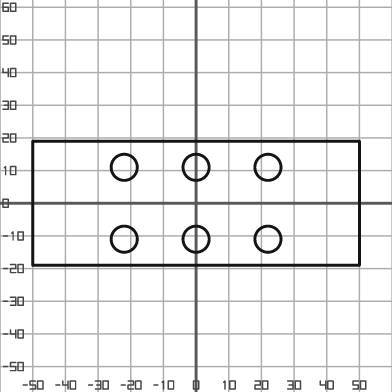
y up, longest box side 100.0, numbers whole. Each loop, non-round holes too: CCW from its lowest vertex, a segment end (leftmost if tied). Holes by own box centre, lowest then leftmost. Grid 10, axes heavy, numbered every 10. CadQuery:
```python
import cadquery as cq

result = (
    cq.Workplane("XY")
    .moveTo(-50.0, -19.0)
    .lineTo(50.0, -19.0)
    .lineTo(50.0, 19.0)
    .lineTo(-50.0, 19.0)
    .close()
    .moveTo(-22.0, -11.0)
    .circle(4.0)
    .moveTo(0.0, -11.0)
    .circle(4.0)
    .moveTo(22.0, -11.0)
    .circle(4.0)
    .moveTo(-22.0, 11.0)
    .circle(4.0)
    .moveTo(0.0, 11.0)
    .circle(4.0)
    .moveTo(22.0, 11.0)
    .circle(4.0)
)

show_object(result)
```